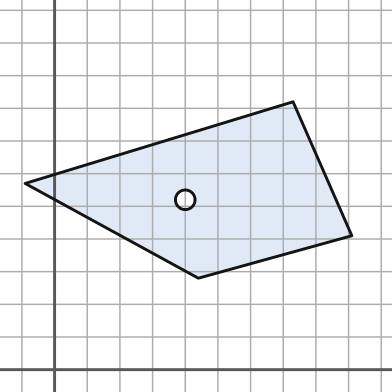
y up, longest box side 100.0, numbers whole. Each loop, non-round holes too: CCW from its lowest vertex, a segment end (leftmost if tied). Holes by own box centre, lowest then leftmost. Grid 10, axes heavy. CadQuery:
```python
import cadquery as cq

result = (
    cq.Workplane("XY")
    .moveTo(44.0, 28.0)
    .lineTo(91.0, 41.0)
    .lineTo(73.0, 82.0)
    .lineTo(-9.0, 57.0)
    .close()
    .moveTo(40.0, 52.0)
    .circle(3.0)
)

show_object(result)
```